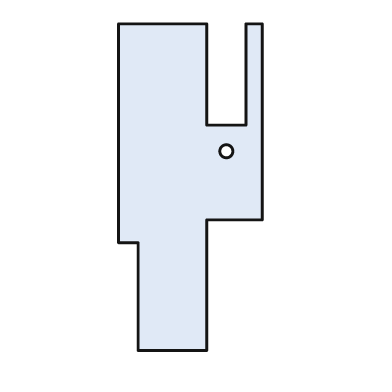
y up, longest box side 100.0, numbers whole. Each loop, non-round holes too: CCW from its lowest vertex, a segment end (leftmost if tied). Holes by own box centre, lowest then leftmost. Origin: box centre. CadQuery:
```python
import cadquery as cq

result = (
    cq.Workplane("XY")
    .moveTo(-16.0, -50.0)
    .lineTo(5.0, -50.0)
    .lineTo(5.0, -10.0)
    .lineTo(22.0, -10.0)
    .lineTo(22.0, 50.0)
    .lineTo(17.0, 50.0)
    .lineTo(17.0, 19.0)
    .lineTo(5.0, 19.0)
    .lineTo(5.0, 50.0)
    .lineTo(-22.0, 50.0)
    .lineTo(-22.0, -17.0)
    .lineTo(-16.0, -17.0)
    .close()
    .moveTo(11.0, 11.0)
    .circle(2.0)
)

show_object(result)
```